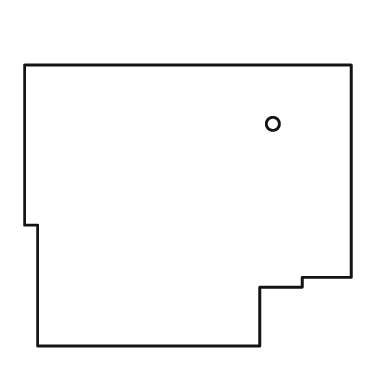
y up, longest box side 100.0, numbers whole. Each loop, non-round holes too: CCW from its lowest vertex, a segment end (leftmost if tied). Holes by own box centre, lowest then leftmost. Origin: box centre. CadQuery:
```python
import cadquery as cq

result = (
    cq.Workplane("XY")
    .moveTo(-46.0, -43.0)
    .lineTo(22.0, -43.0)
    .lineTo(22.0, -25.0)
    .lineTo(35.0, -25.0)
    .lineTo(35.0, -22.0)
    .lineTo(50.0, -22.0)
    .lineTo(50.0, 43.0)
    .lineTo(-50.0, 43.0)
    .lineTo(-50.0, -6.0)
    .lineTo(-46.0, -6.0)
    .close()
    .moveTo(26.0, 25.0)
    .circle(2.0)
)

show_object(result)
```